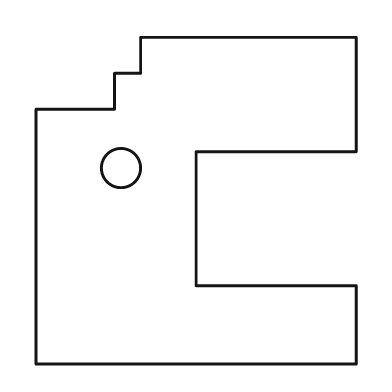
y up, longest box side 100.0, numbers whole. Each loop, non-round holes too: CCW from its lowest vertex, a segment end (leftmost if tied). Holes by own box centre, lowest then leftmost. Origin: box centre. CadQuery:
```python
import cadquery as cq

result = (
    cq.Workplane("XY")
    .moveTo(-49.0, -50.0)
    .lineTo(49.0, -50.0)
    .lineTo(49.0, -26.0)
    .lineTo(0.0, -26.0)
    .lineTo(0.0, 15.0)
    .lineTo(49.0, 15.0)
    .lineTo(49.0, 50.0)
    .lineTo(-17.0, 50.0)
    .lineTo(-17.0, 39.0)
    .lineTo(-25.0, 39.0)
    .lineTo(-25.0, 28.0)
    .lineTo(-49.0, 28.0)
    .close()
    .moveTo(-23.0, 10.0)
    .circle(6.0)
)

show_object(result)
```